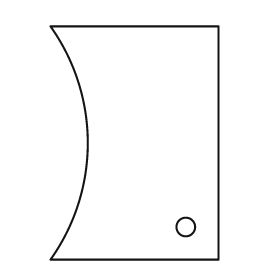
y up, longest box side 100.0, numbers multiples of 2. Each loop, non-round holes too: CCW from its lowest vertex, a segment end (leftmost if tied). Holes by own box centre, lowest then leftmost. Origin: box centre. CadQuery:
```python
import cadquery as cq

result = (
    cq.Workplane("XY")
    .moveTo(-36.0, -50.0)
    .lineTo(36.0, -50.0)
    .lineTo(36.0, 50.0)
    .lineTo(-36.0, 50.0)
    .threePointArc((-20.0, 0.0), (-36.0, -50.0))
    .close()
    .moveTo(22.0, -36.0)
    .circle(4.0)
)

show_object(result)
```